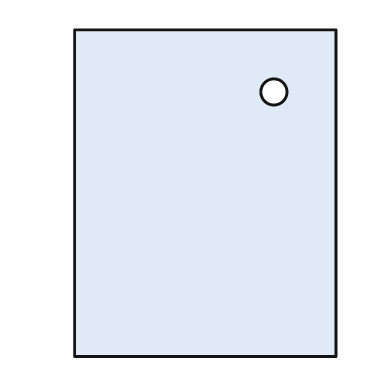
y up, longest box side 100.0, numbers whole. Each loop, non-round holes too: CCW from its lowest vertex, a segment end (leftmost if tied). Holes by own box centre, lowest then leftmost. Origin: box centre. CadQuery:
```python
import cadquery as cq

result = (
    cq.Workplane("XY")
    .moveTo(-40.0, -50.0)
    .lineTo(40.0, -50.0)
    .lineTo(40.0, 50.0)
    .lineTo(-40.0, 50.0)
    .close()
    .moveTo(21.0, 31.0)
    .circle(4.0)
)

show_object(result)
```